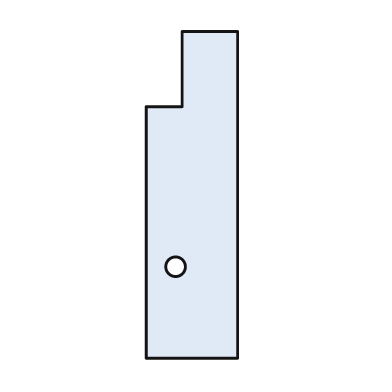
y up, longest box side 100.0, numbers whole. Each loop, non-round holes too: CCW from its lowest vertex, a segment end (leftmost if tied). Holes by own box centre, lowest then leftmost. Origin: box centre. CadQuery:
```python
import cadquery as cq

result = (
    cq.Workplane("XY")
    .moveTo(-14.0, -50.0)
    .lineTo(14.0, -50.0)
    .lineTo(14.0, 50.0)
    .lineTo(-3.0, 50.0)
    .lineTo(-3.0, 27.0)
    .lineTo(-14.0, 27.0)
    .close()
    .moveTo(-5.0, -22.0)
    .circle(3.0)
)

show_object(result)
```